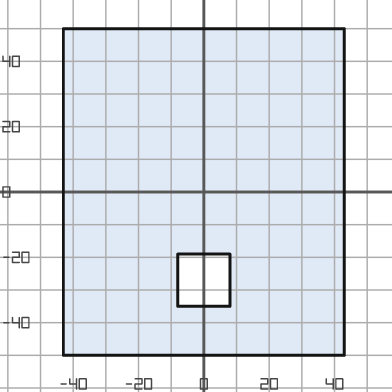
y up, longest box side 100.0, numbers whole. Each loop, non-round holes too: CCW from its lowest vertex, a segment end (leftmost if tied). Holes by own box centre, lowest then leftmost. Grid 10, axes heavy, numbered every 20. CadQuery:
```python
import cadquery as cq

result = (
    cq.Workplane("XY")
    .moveTo(-43.0, -50.0)
    .lineTo(43.0, -50.0)
    .lineTo(43.0, 50.0)
    .lineTo(-43.0, 50.0)
    .close()
    .moveTo(-8.0, -35.0)
    .lineTo(8.0, -35.0)
    .lineTo(8.0, -19.0)
    .lineTo(-8.0, -19.0)
    .close()
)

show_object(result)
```